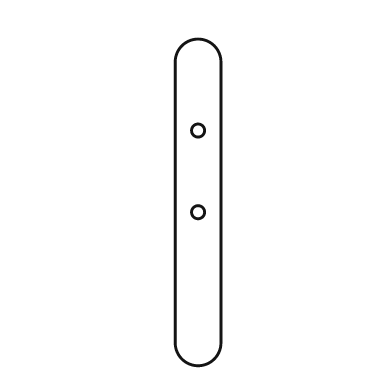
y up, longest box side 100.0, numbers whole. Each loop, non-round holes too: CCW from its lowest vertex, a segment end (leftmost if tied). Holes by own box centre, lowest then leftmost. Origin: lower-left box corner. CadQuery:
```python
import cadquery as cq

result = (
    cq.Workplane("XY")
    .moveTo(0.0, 7.0)
    .threePointArc((7.0, 0.0), (14.0, 7.0))
    .lineTo(14.0, 93.0)
    .threePointArc((7.0, 100.0), (0.0, 93.0))
    .close()
    .moveTo(7.0, 47.0)
    .circle(2.0)
    .moveTo(7.0, 72.0)
    .circle(2.0)
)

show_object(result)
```